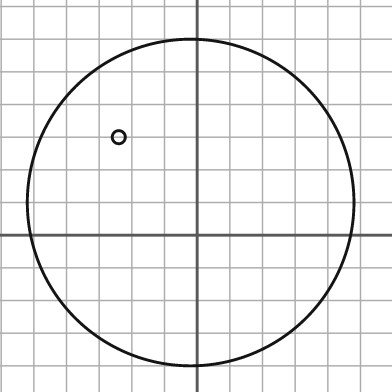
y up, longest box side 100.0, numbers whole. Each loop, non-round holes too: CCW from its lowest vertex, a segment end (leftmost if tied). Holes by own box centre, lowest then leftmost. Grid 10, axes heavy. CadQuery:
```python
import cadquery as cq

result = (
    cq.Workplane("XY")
    .moveTo(-2.0, 10.0)
    .circle(50.0)
    .moveTo(-24.0, 30.0)
    .circle(2.0)
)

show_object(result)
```